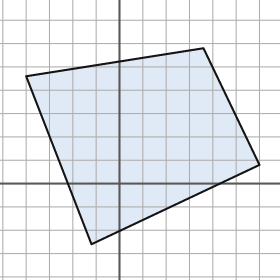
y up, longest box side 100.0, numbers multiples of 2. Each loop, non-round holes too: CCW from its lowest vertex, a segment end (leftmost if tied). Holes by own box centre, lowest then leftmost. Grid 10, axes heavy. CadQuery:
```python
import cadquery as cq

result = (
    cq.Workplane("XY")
    .moveTo(-12.0, -26.0)
    .lineTo(60.0, 8.0)
    .lineTo(36.0, 58.0)
    .lineTo(-40.0, 46.0)
    .close()
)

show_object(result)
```